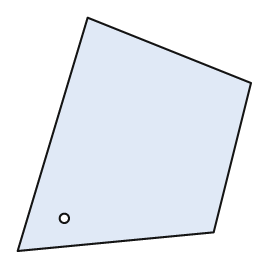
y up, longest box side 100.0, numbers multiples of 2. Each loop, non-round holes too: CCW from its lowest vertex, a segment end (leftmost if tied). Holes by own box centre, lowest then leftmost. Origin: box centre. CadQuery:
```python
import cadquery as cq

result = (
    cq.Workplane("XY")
    .moveTo(-50.0, -50.0)
    .lineTo(34.0, -42.0)
    .lineTo(50.0, 22.0)
    .lineTo(-20.0, 50.0)
    .close()
    .moveTo(-30.0, -36.0)
    .circle(2.0)
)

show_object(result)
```